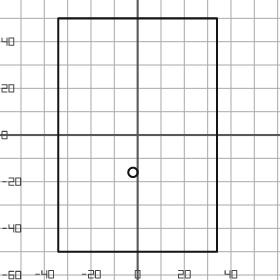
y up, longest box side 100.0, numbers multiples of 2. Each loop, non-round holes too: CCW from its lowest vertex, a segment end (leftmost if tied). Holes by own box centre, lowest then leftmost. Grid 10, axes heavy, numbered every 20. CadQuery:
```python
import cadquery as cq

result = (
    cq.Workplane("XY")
    .moveTo(-34.0, -50.0)
    .lineTo(34.0, -50.0)
    .lineTo(34.0, 50.0)
    .lineTo(-34.0, 50.0)
    .close()
    .moveTo(-2.0, -16.0)
    .circle(2.0)
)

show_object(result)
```